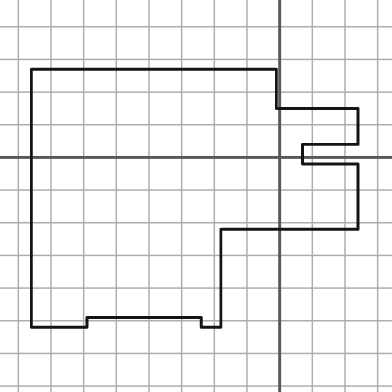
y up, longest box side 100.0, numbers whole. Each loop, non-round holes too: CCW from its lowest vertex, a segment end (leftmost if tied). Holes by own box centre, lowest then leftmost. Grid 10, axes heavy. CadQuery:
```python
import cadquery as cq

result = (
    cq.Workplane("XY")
    .moveTo(-76.0, -52.0)
    .lineTo(-59.0, -52.0)
    .lineTo(-59.0, -49.0)
    .lineTo(-24.0, -49.0)
    .lineTo(-24.0, -52.0)
    .lineTo(-18.0, -52.0)
    .lineTo(-18.0, -22.0)
    .lineTo(24.0, -22.0)
    .lineTo(24.0, -2.0)
    .lineTo(7.0, -2.0)
    .lineTo(7.0, 4.0)
    .lineTo(24.0, 4.0)
    .lineTo(24.0, 15.0)
    .lineTo(-1.0, 15.0)
    .lineTo(-1.0, 27.0)
    .lineTo(-76.0, 27.0)
    .close()
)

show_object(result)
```